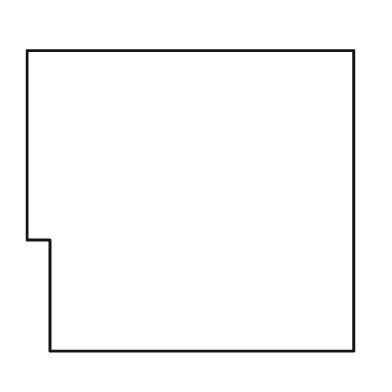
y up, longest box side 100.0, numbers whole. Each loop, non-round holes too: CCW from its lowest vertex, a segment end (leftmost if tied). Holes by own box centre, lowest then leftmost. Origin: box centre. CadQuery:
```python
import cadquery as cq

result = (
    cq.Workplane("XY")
    .moveTo(-43.0, -46.0)
    .lineTo(50.0, -46.0)
    .lineTo(50.0, 46.0)
    .lineTo(-50.0, 46.0)
    .lineTo(-50.0, -12.0)
    .lineTo(-43.0, -12.0)
    .close()
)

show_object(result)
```